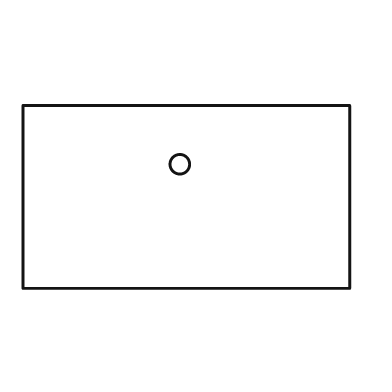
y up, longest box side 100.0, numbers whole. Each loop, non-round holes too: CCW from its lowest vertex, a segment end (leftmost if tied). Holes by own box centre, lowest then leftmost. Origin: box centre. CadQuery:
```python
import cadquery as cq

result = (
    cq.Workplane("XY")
    .moveTo(-50.0, -28.0)
    .lineTo(50.0, -28.0)
    .lineTo(50.0, 28.0)
    .lineTo(-50.0, 28.0)
    .close()
    .moveTo(-2.0, 10.0)
    .circle(3.0)
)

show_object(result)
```